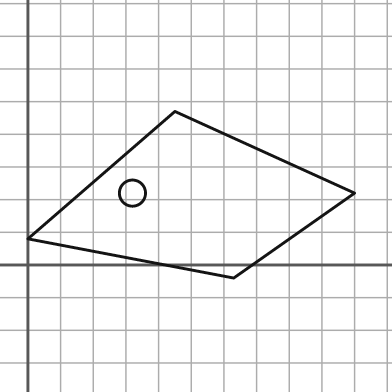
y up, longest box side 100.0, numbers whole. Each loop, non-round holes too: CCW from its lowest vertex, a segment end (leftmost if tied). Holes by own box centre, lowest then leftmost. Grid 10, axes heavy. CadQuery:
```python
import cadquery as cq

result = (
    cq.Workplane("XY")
    .moveTo(63.0, -4.0)
    .lineTo(100.0, 22.0)
    .lineTo(45.0, 47.0)
    .lineTo(0.0, 8.0)
    .close()
    .moveTo(32.0, 22.0)
    .circle(4.0)
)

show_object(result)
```